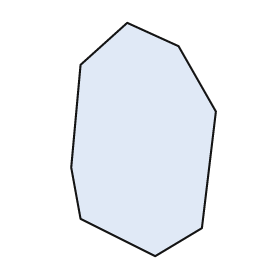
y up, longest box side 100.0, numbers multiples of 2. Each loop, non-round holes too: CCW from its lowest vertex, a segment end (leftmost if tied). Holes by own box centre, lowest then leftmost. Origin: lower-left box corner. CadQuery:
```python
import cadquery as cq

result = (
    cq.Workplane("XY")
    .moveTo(36.0, 0.0)
    .lineTo(56.0, 12.0)
    .lineTo(62.0, 62.0)
    .lineTo(46.0, 90.0)
    .lineTo(24.0, 100.0)
    .lineTo(4.0, 82.0)
    .lineTo(0.0, 38.0)
    .lineTo(4.0, 16.0)
    .close()
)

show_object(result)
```